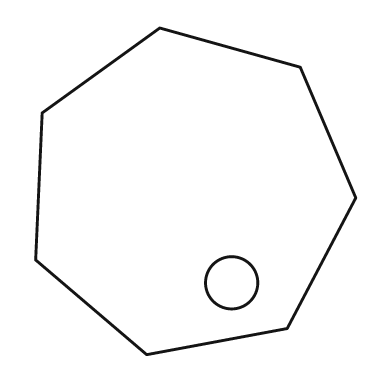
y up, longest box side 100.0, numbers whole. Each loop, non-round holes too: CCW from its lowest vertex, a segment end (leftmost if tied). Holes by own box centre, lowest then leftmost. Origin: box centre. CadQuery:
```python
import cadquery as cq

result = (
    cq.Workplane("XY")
    .moveTo(-15.0, -50.0)
    .lineTo(28.0, -42.0)
    .lineTo(49.0, -2.0)
    .lineTo(32.0, 38.0)
    .lineTo(-11.0, 50.0)
    .lineTo(-47.0, 24.0)
    .lineTo(-49.0, -21.0)
    .close()
    .moveTo(11.0, -28.0)
    .circle(8.0)
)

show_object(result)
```